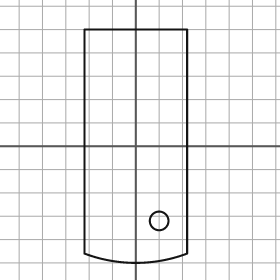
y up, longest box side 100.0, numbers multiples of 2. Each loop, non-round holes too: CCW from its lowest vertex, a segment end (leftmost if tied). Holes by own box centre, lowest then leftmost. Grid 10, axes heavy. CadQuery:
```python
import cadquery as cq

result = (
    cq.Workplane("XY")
    .moveTo(-22.0, -46.0)
    .threePointArc((0.0, -50.0), (22.0, -46.0))
    .lineTo(22.0, 50.0)
    .lineTo(-22.0, 50.0)
    .close()
    .moveTo(10.0, -32.0)
    .circle(4.0)
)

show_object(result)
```